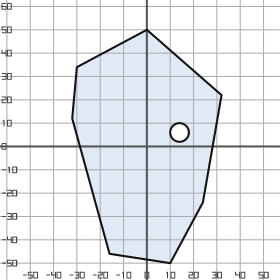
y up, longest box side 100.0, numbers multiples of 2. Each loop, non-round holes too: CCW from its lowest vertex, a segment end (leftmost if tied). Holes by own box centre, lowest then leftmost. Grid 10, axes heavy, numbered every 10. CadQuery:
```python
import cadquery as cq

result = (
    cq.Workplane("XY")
    .moveTo(10.0, -50.0)
    .lineTo(24.0, -24.0)
    .lineTo(32.0, 22.0)
    .lineTo(0.0, 50.0)
    .lineTo(-30.0, 34.0)
    .lineTo(-32.0, 12.0)
    .lineTo(-16.0, -46.0)
    .close()
    .moveTo(14.0, 6.0)
    .circle(4.0)
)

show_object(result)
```